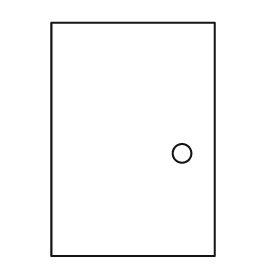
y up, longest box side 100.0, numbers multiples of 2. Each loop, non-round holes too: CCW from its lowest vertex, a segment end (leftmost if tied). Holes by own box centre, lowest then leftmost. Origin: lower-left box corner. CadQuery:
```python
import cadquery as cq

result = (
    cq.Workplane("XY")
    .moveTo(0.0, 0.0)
    .lineTo(70.0, 0.0)
    .lineTo(70.0, 100.0)
    .lineTo(0.0, 100.0)
    .close()
    .moveTo(56.0, 44.0)
    .circle(4.0)
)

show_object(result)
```